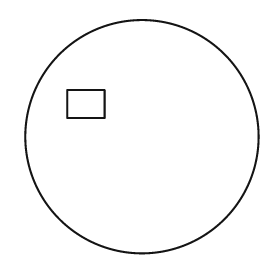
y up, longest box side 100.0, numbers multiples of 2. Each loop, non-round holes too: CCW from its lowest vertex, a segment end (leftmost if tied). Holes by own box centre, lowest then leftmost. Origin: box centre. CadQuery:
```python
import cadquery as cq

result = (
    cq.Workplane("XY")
    .moveTo(0.0, 0.0)
    .circle(50.0)
    .moveTo(-32.0, 8.0)
    .lineTo(-16.0, 8.0)
    .lineTo(-16.0, 20.0)
    .lineTo(-32.0, 20.0)
    .close()
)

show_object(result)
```